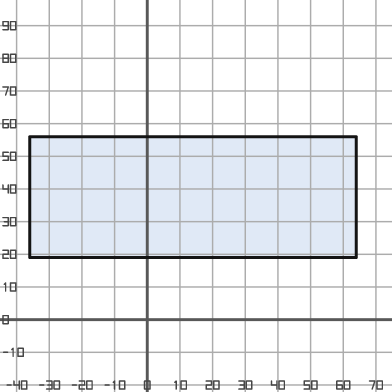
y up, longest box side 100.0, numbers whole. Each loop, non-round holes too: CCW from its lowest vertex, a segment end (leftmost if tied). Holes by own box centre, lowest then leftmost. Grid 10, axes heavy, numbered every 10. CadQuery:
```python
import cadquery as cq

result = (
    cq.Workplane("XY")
    .moveTo(-36.0, 19.0)
    .lineTo(64.0, 19.0)
    .lineTo(64.0, 56.0)
    .lineTo(-36.0, 56.0)
    .close()
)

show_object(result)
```